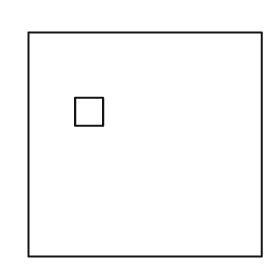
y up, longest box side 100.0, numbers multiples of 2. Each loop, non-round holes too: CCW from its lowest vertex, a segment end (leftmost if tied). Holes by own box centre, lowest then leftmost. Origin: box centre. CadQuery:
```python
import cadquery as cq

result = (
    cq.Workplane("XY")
    .moveTo(-50.0, -48.0)
    .lineTo(50.0, -48.0)
    .lineTo(50.0, 48.0)
    .lineTo(-50.0, 48.0)
    .close()
    .moveTo(-30.0, 8.0)
    .lineTo(-18.0, 8.0)
    .lineTo(-18.0, 20.0)
    .lineTo(-30.0, 20.0)
    .close()
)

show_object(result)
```